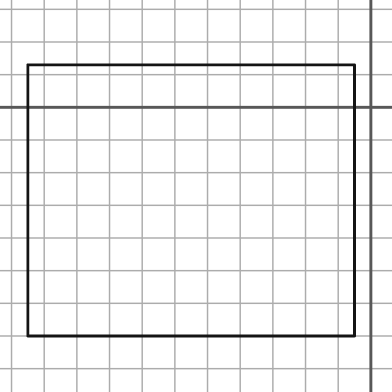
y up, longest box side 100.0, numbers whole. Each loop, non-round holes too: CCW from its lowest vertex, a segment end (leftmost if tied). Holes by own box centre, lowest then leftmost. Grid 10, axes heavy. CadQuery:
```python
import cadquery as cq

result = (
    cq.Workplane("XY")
    .moveTo(-105.0, -70.0)
    .lineTo(-5.0, -70.0)
    .lineTo(-5.0, 13.0)
    .lineTo(-105.0, 13.0)
    .close()
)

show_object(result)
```